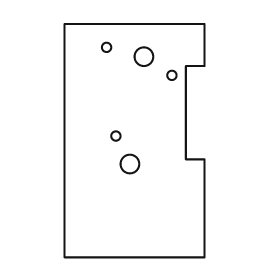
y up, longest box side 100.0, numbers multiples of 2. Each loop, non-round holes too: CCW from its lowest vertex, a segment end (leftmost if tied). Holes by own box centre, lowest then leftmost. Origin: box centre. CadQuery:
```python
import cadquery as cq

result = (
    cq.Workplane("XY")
    .moveTo(-30.0, -50.0)
    .lineTo(30.0, -50.0)
    .lineTo(30.0, -8.0)
    .lineTo(22.0, -8.0)
    .lineTo(22.0, 32.0)
    .lineTo(30.0, 32.0)
    .lineTo(30.0, 50.0)
    .lineTo(-30.0, 50.0)
    .close()
    .moveTo(-2.0, -10.0)
    .circle(4.0)
    .moveTo(-8.0, 2.0)
    .circle(2.0)
    .moveTo(16.0, 28.0)
    .circle(2.0)
    .moveTo(4.0, 36.0)
    .circle(4.0)
    .moveTo(-12.0, 40.0)
    .circle(2.0)
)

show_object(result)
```